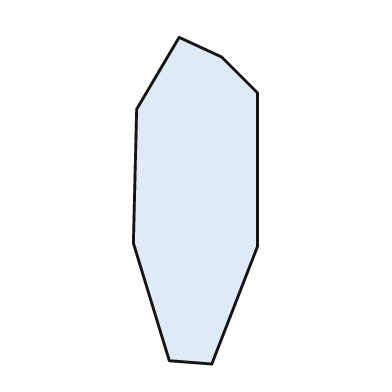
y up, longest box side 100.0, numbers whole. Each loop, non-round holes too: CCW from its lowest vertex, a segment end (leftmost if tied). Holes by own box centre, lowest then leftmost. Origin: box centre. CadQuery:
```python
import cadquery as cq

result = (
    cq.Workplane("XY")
    .moveTo(5.0, -50.0)
    .lineTo(19.0, -14.0)
    .lineTo(19.0, 33.0)
    .lineTo(8.0, 44.0)
    .lineTo(-5.0, 50.0)
    .lineTo(-18.0, 28.0)
    .lineTo(-19.0, -13.0)
    .lineTo(-8.0, -49.0)
    .close()
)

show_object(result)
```